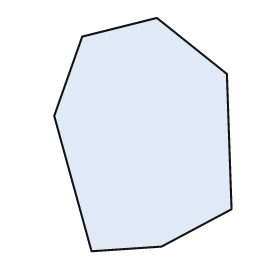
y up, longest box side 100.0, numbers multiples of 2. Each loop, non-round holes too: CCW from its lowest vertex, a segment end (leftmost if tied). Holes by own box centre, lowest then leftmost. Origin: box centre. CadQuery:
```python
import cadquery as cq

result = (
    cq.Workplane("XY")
    .moveTo(-22.0, -50.0)
    .lineTo(8.0, -48.0)
    .lineTo(38.0, -32.0)
    .lineTo(36.0, 26.0)
    .lineTo(6.0, 50.0)
    .lineTo(-26.0, 42.0)
    .lineTo(-38.0, 8.0)
    .close()
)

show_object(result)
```